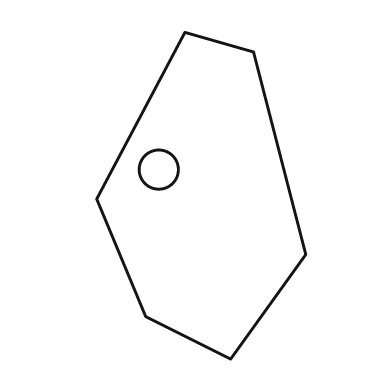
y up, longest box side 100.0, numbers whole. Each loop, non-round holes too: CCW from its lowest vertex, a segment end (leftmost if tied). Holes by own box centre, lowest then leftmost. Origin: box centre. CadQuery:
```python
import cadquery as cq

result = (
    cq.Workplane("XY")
    .moveTo(9.0, -50.0)
    .lineTo(32.0, -18.0)
    .lineTo(16.0, 44.0)
    .lineTo(-5.0, 50.0)
    .lineTo(-32.0, -1.0)
    .lineTo(-17.0, -37.0)
    .close()
    .moveTo(-13.0, 8.0)
    .circle(6.0)
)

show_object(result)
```